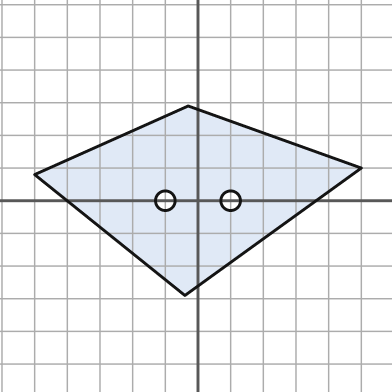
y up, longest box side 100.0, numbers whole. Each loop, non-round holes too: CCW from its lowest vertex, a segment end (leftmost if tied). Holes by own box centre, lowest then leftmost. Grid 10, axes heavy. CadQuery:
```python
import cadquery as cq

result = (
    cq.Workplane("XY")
    .moveTo(-4.0, -29.0)
    .lineTo(50.0, 10.0)
    .lineTo(-3.0, 29.0)
    .lineTo(-50.0, 8.0)
    .close()
    .moveTo(-10.0, 0.0)
    .circle(3.0)
    .moveTo(10.0, 0.0)
    .circle(3.0)
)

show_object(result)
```